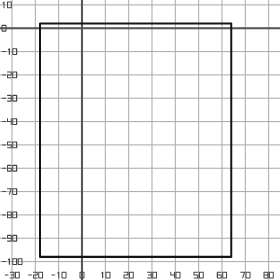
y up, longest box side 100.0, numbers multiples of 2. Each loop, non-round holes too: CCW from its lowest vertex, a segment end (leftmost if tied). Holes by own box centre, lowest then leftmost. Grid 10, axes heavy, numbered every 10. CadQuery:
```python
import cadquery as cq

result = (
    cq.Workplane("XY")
    .moveTo(-18.0, -98.0)
    .lineTo(64.0, -98.0)
    .lineTo(64.0, 2.0)
    .lineTo(-18.0, 2.0)
    .close()
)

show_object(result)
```